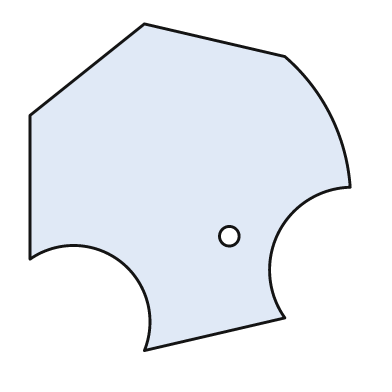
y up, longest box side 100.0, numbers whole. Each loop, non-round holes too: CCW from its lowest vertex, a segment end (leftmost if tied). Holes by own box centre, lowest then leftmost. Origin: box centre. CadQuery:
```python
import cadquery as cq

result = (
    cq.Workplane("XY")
    .moveTo(-14.0, -50.0)
    .lineTo(29.0, -40.0)
    .threePointArc((27.0, -14.0), (49.0, 0.0))
    .threePointArc((43.0, 22.0), (29.0, 40.0))
    .lineTo(-14.0, 50.0)
    .lineTo(-49.0, 22.0)
    .lineTo(-49.0, -22.0)
    .threePointArc((-21.0, -23.0), (-14.0, -50.0))
    .close()
    .moveTo(12.0, -15.0)
    .circle(3.0)
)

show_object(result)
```